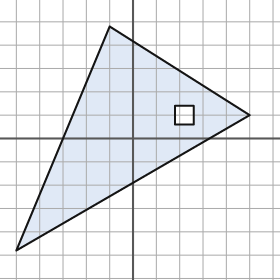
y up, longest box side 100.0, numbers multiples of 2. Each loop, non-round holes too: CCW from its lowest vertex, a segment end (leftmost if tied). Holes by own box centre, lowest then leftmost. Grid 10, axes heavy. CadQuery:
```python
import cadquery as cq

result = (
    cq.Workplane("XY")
    .moveTo(-50.0, -48.0)
    .lineTo(50.0, 10.0)
    .lineTo(-10.0, 48.0)
    .close()
    .moveTo(18.0, 6.0)
    .lineTo(26.0, 6.0)
    .lineTo(26.0, 14.0)
    .lineTo(18.0, 14.0)
    .close()
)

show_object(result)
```